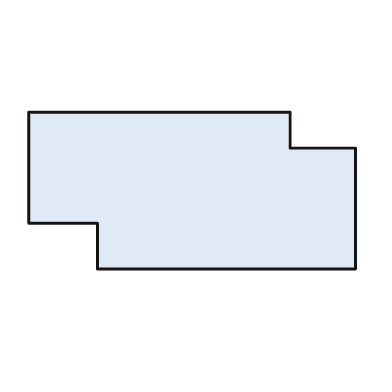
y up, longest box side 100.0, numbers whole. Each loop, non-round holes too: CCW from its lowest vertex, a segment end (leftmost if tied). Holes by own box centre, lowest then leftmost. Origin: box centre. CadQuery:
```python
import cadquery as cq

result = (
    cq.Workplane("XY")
    .moveTo(-29.0, -24.0)
    .lineTo(50.0, -24.0)
    .lineTo(50.0, 13.0)
    .lineTo(30.0, 13.0)
    .lineTo(30.0, 24.0)
    .lineTo(-50.0, 24.0)
    .lineTo(-50.0, -10.0)
    .lineTo(-29.0, -10.0)
    .close()
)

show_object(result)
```